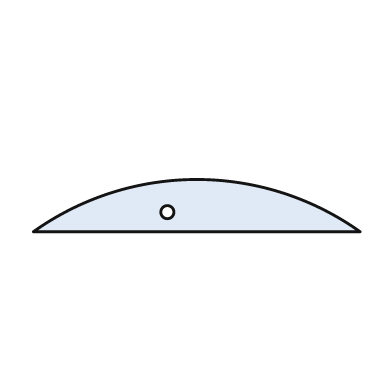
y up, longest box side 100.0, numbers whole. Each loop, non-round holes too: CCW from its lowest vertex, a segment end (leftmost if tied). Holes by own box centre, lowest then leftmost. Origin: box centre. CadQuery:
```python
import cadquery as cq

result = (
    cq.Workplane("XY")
    .moveTo(-50.0, -8.0)
    .lineTo(50.0, -8.0)
    .threePointArc((0.0, 8.0), (-50.0, -8.0))
    .close()
    .moveTo(-9.0, -2.0)
    .circle(2.0)
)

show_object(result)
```